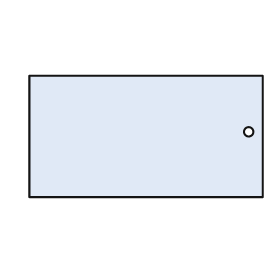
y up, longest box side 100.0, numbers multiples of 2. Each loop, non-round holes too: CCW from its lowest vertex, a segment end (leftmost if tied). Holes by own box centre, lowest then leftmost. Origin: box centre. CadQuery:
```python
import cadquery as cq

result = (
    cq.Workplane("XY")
    .moveTo(-50.0, -26.0)
    .lineTo(50.0, -26.0)
    .lineTo(50.0, 26.0)
    .lineTo(-50.0, 26.0)
    .close()
    .moveTo(44.0, 2.0)
    .circle(2.0)
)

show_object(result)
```